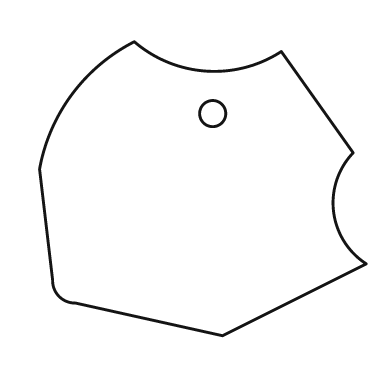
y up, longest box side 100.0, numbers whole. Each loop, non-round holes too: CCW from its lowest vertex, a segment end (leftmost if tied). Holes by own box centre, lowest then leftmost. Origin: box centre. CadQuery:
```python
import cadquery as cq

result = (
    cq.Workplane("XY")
    .moveTo(6.0, -45.0)
    .lineTo(50.0, -23.0)
    .threePointArc((40.0, -7.0), (46.0, 11.0))
    .lineTo(24.0, 42.0)
    .threePointArc((1.0, 36.0), (-21.0, 45.0))
    .threePointArc((-40.0, 29.0), (-50.0, 6.0))
    .lineTo(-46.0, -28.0)
    .threePointArc((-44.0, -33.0), (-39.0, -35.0))
    .close()
    .moveTo(3.0, 23.0)
    .circle(4.0)
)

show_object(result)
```